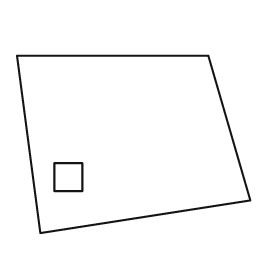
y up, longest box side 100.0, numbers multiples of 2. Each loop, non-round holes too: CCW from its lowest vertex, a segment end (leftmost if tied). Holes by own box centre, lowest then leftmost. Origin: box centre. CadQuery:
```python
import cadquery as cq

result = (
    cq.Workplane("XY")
    .moveTo(-40.0, -38.0)
    .lineTo(50.0, -24.0)
    .lineTo(32.0, 38.0)
    .lineTo(-50.0, 38.0)
    .close()
    .moveTo(-34.0, -20.0)
    .lineTo(-22.0, -20.0)
    .lineTo(-22.0, -8.0)
    .lineTo(-34.0, -8.0)
    .close()
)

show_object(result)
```